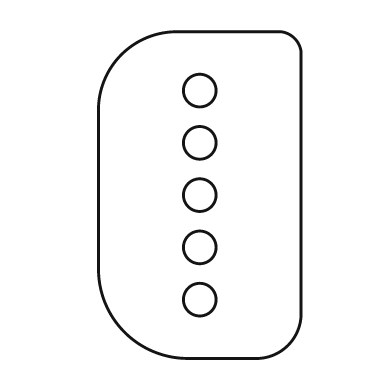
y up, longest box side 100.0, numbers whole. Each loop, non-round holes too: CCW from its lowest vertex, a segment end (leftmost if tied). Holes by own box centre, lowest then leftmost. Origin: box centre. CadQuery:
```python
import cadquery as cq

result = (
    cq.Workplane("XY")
    .moveTo(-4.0, -50.0)
    .lineTo(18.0, -50.0)
    .threePointArc((27.0, -46.0), (31.0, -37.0))
    .lineTo(31.0, 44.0)
    .threePointArc((29.0, 48.0), (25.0, 50.0))
    .lineTo(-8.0, 50.0)
    .threePointArc((-24.0, 43.0), (-31.0, 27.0))
    .lineTo(-31.0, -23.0)
    .threePointArc((-23.0, -42.0), (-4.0, -50.0))
    .close()
    .moveTo(0.0, -32.0)
    .circle(5.0)
    .moveTo(0.0, -16.0)
    .circle(5.0)
    .moveTo(0.0, 0.0)
    .circle(5.0)
    .moveTo(0.0, 16.0)
    .circle(5.0)
    .moveTo(0.0, 32.0)
    .circle(5.0)
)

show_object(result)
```